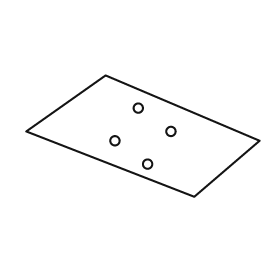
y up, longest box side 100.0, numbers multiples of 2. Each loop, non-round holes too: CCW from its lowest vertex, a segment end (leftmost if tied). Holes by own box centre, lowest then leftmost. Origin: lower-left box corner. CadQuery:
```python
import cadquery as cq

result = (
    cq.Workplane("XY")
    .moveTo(72.0, 0.0)
    .lineTo(100.0, 24.0)
    .lineTo(34.0, 52.0)
    .lineTo(0.0, 28.0)
    .close()
    .moveTo(52.0, 14.0)
    .circle(2.0)
    .moveTo(38.0, 24.0)
    .circle(2.0)
    .moveTo(62.0, 28.0)
    .circle(2.0)
    .moveTo(48.0, 38.0)
    .circle(2.0)
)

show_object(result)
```